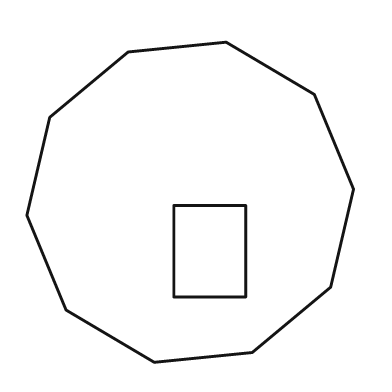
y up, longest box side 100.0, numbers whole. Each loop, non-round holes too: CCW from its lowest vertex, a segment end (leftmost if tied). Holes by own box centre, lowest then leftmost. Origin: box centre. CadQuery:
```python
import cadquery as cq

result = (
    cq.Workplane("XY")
    .moveTo(-11.0, -49.0)
    .lineTo(19.0, -46.0)
    .lineTo(43.0, -26.0)
    .lineTo(50.0, 4.0)
    .lineTo(38.0, 33.0)
    .lineTo(11.0, 49.0)
    .lineTo(-19.0, 46.0)
    .lineTo(-43.0, 26.0)
    .lineTo(-50.0, -4.0)
    .lineTo(-38.0, -33.0)
    .close()
    .moveTo(-5.0, -29.0)
    .lineTo(17.0, -29.0)
    .lineTo(17.0, -1.0)
    .lineTo(-5.0, -1.0)
    .close()
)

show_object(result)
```